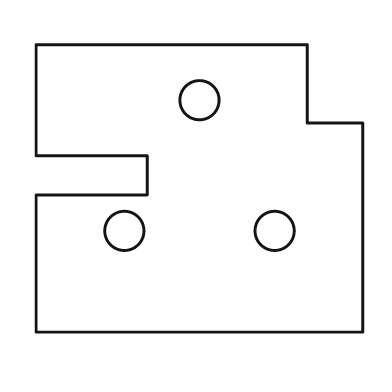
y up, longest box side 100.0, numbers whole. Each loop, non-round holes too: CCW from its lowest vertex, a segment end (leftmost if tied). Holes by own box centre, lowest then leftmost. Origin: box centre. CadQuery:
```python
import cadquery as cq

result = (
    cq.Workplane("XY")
    .moveTo(-50.0, -44.0)
    .lineTo(50.0, -44.0)
    .lineTo(50.0, 20.0)
    .lineTo(33.0, 20.0)
    .lineTo(33.0, 44.0)
    .lineTo(-50.0, 44.0)
    .lineTo(-50.0, 10.0)
    .lineTo(-16.0, 10.0)
    .lineTo(-16.0, -2.0)
    .lineTo(-50.0, -2.0)
    .close()
    .moveTo(-23.0, -13.0)
    .circle(6.0)
    .moveTo(23.0, -13.0)
    .circle(6.0)
    .moveTo(0.0, 27.0)
    .circle(6.0)
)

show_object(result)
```